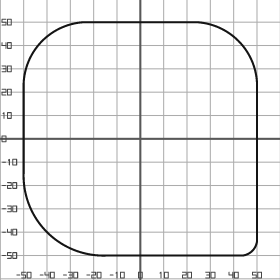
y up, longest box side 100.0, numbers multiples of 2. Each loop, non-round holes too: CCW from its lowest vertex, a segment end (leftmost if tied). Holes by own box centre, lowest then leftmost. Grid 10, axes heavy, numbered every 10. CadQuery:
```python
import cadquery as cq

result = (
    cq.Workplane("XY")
    .moveTo(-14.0, -50.0)
    .lineTo(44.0, -50.0)
    .threePointArc((48.0, -48.0), (50.0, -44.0))
    .lineTo(50.0, 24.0)
    .threePointArc((42.0, 42.0), (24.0, 50.0))
    .lineTo(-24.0, 50.0)
    .threePointArc((-42.0, 42.0), (-50.0, 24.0))
    .lineTo(-50.0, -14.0)
    .threePointArc((-40.0, -40.0), (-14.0, -50.0))
    .close()
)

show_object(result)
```